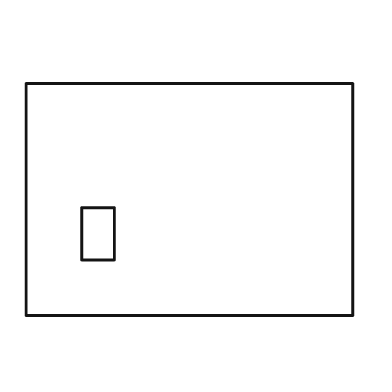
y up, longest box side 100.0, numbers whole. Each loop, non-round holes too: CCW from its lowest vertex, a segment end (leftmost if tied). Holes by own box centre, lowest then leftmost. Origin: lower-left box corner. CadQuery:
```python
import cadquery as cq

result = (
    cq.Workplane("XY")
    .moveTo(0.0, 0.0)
    .lineTo(100.0, 0.0)
    .lineTo(100.0, 71.0)
    .lineTo(0.0, 71.0)
    .close()
    .moveTo(17.0, 17.0)
    .lineTo(27.0, 17.0)
    .lineTo(27.0, 33.0)
    .lineTo(17.0, 33.0)
    .close()
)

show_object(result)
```